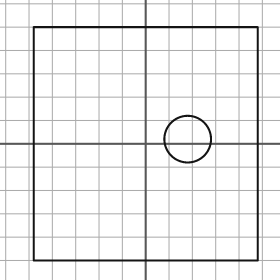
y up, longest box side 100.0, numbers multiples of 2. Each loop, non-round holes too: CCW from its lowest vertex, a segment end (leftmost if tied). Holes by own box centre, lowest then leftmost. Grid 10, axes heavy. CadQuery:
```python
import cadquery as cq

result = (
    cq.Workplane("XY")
    .moveTo(-48.0, -50.0)
    .lineTo(48.0, -50.0)
    .lineTo(48.0, 50.0)
    .lineTo(-48.0, 50.0)
    .close()
    .moveTo(18.0, 2.0)
    .circle(10.0)
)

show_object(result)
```